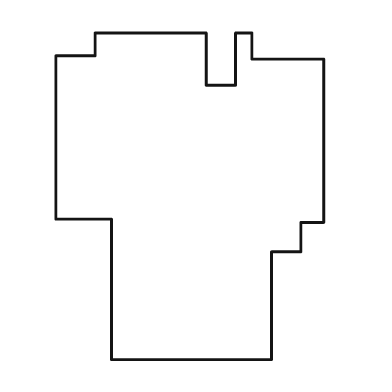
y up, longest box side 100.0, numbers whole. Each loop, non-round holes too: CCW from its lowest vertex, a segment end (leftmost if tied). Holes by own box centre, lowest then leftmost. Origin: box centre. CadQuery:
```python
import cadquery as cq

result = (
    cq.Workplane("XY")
    .moveTo(-24.0, -50.0)
    .lineTo(25.0, -50.0)
    .lineTo(25.0, -17.0)
    .lineTo(34.0, -17.0)
    .lineTo(34.0, -8.0)
    .lineTo(41.0, -8.0)
    .lineTo(41.0, 42.0)
    .lineTo(19.0, 42.0)
    .lineTo(19.0, 50.0)
    .lineTo(14.0, 50.0)
    .lineTo(14.0, 34.0)
    .lineTo(5.0, 34.0)
    .lineTo(5.0, 50.0)
    .lineTo(-29.0, 50.0)
    .lineTo(-29.0, 43.0)
    .lineTo(-41.0, 43.0)
    .lineTo(-41.0, -7.0)
    .lineTo(-24.0, -7.0)
    .close()
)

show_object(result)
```